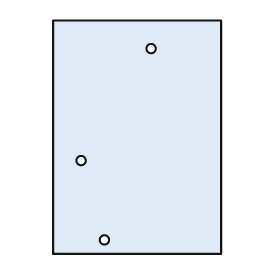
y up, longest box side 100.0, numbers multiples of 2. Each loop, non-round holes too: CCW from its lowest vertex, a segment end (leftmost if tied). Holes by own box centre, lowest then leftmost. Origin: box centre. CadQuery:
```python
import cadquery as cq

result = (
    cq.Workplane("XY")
    .moveTo(-36.0, -50.0)
    .lineTo(36.0, -50.0)
    .lineTo(36.0, 50.0)
    .lineTo(-36.0, 50.0)
    .close()
    .moveTo(-14.0, -44.0)
    .circle(2.0)
    .moveTo(-24.0, -10.0)
    .circle(2.0)
    .moveTo(6.0, 38.0)
    .circle(2.0)
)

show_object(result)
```